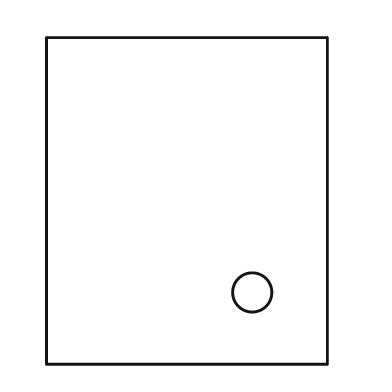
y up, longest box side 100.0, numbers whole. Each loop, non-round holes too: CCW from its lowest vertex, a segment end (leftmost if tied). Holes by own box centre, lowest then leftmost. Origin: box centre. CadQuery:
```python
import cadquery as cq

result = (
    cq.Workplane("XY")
    .moveTo(-43.0, -50.0)
    .lineTo(43.0, -50.0)
    .lineTo(43.0, 50.0)
    .lineTo(-43.0, 50.0)
    .close()
    .moveTo(20.0, -28.0)
    .circle(6.0)
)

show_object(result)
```